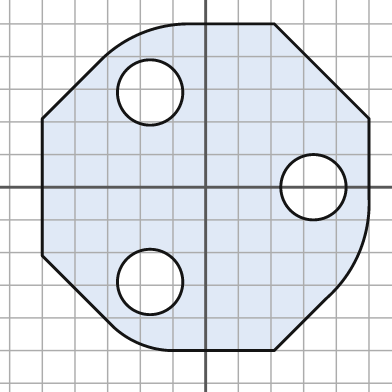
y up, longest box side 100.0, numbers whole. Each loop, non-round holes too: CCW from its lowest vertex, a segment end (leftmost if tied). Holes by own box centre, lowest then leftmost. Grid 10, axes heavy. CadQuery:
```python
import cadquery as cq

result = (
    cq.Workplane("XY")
    .moveTo(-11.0, -50.0)
    .lineTo(21.0, -50.0)
    .lineTo(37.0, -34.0)
    .threePointArc((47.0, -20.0), (50.0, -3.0))
    .lineTo(50.0, 21.0)
    .lineTo(21.0, 50.0)
    .lineTo(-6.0, 50.0)
    .threePointArc((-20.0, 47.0), (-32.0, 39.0))
    .lineTo(-50.0, 21.0)
    .lineTo(-50.0, -21.0)
    .lineTo(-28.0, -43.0)
    .threePointArc((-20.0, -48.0), (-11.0, -50.0))
    .close()
    .moveTo(-17.0, -29.0)
    .circle(10.0)
    .moveTo(33.0, 0.0)
    .circle(10.0)
    .moveTo(-17.0, 29.0)
    .circle(10.0)
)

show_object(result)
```